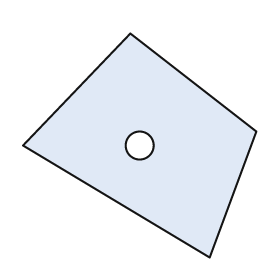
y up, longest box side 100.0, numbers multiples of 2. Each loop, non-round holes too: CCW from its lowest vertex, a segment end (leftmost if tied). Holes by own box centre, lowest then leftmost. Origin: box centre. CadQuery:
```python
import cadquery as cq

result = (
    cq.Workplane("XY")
    .moveTo(30.0, -48.0)
    .lineTo(50.0, 6.0)
    .lineTo(-4.0, 48.0)
    .lineTo(-50.0, 0.0)
    .close()
    .moveTo(0.0, 0.0)
    .circle(6.0)
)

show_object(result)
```